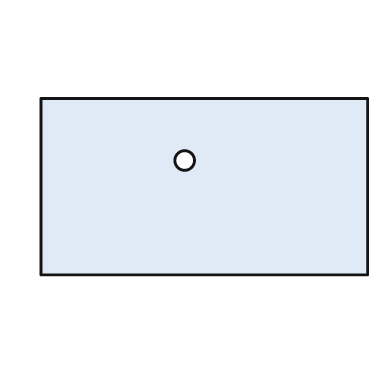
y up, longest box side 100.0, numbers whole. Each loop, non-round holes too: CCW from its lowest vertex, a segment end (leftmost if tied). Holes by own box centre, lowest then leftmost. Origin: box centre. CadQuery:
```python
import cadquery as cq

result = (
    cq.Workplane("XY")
    .moveTo(-50.0, -27.0)
    .lineTo(50.0, -27.0)
    .lineTo(50.0, 27.0)
    .lineTo(-50.0, 27.0)
    .close()
    .moveTo(-6.0, 8.0)
    .circle(3.0)
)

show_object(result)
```